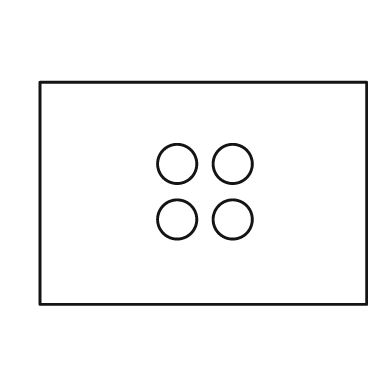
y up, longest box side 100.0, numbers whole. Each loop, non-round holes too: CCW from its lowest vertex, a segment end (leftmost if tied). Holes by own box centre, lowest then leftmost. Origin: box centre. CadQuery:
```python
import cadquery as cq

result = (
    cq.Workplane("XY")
    .moveTo(-50.0, -34.0)
    .lineTo(50.0, -34.0)
    .lineTo(50.0, 34.0)
    .lineTo(-50.0, 34.0)
    .close()
    .moveTo(-8.0, -8.0)
    .circle(6.0)
    .moveTo(9.0, -8.0)
    .circle(6.0)
    .moveTo(-8.0, 9.0)
    .circle(6.0)
    .moveTo(9.0, 9.0)
    .circle(6.0)
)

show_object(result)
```